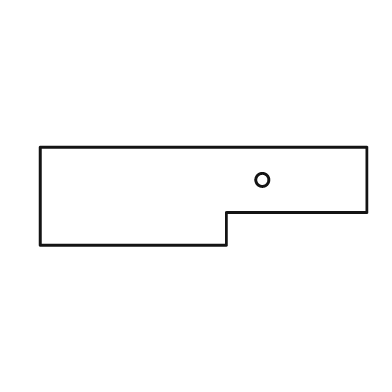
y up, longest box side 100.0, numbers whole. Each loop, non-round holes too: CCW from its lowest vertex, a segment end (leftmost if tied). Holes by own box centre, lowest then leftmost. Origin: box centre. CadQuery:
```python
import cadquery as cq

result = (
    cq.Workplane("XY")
    .moveTo(-50.0, -15.0)
    .lineTo(7.0, -15.0)
    .lineTo(7.0, -5.0)
    .lineTo(50.0, -5.0)
    .lineTo(50.0, 15.0)
    .lineTo(-50.0, 15.0)
    .close()
    .moveTo(18.0, 5.0)
    .circle(2.0)
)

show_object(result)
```